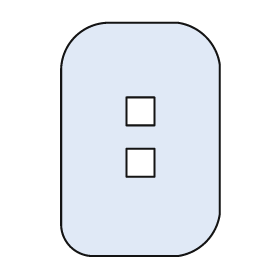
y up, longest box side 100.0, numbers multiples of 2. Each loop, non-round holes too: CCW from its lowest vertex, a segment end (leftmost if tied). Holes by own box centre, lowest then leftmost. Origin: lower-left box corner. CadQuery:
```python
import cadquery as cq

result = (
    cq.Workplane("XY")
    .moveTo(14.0, 0.0)
    .lineTo(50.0, 0.0)
    .threePointArc((62.0, 6.0), (68.0, 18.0))
    .lineTo(68.0, 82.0)
    .threePointArc((62.0, 94.0), (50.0, 100.0))
    .lineTo(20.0, 100.0)
    .threePointArc((6.0, 94.0), (0.0, 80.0))
    .lineTo(0.0, 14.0)
    .threePointArc((4.0, 4.0), (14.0, 0.0))
    .close()
    .moveTo(28.0, 34.0)
    .lineTo(40.0, 34.0)
    .lineTo(40.0, 46.0)
    .lineTo(28.0, 46.0)
    .close()
    .moveTo(28.0, 56.0)
    .lineTo(40.0, 56.0)
    .lineTo(40.0, 68.0)
    .lineTo(28.0, 68.0)
    .close()
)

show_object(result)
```